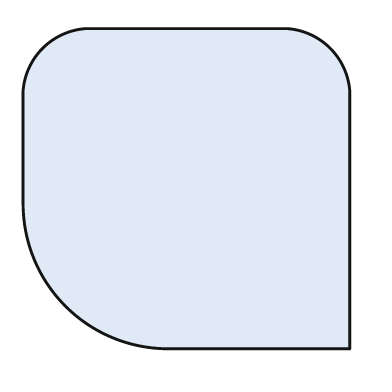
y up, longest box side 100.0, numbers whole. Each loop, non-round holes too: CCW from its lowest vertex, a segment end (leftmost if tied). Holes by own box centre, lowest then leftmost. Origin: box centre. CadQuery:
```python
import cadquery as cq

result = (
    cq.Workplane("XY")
    .moveTo(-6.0, -49.0)
    .lineTo(50.0, -49.0)
    .lineTo(50.0, 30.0)
    .threePointArc((44.0, 43.0), (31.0, 49.0))
    .lineTo(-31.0, 49.0)
    .threePointArc((-44.0, 43.0), (-50.0, 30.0))
    .lineTo(-50.0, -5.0)
    .threePointArc((-37.0, -36.0), (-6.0, -49.0))
    .close()
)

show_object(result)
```